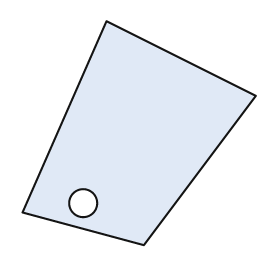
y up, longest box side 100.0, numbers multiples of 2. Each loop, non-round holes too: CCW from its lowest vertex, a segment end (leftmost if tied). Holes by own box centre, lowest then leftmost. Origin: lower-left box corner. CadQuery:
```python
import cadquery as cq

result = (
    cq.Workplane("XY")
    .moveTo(52.0, 0.0)
    .lineTo(100.0, 64.0)
    .lineTo(36.0, 96.0)
    .lineTo(0.0, 14.0)
    .close()
    .moveTo(26.0, 18.0)
    .circle(6.0)
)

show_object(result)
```